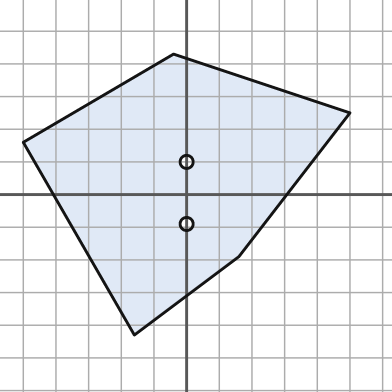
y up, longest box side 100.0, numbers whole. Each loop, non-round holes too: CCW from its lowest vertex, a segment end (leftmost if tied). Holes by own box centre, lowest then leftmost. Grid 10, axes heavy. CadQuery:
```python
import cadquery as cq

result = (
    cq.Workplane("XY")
    .moveTo(-16.0, -43.0)
    .lineTo(16.0, -19.0)
    .lineTo(50.0, 25.0)
    .lineTo(-4.0, 43.0)
    .lineTo(-50.0, 16.0)
    .close()
    .moveTo(0.0, -9.0)
    .circle(2.0)
    .moveTo(0.0, 10.0)
    .circle(2.0)
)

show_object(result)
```